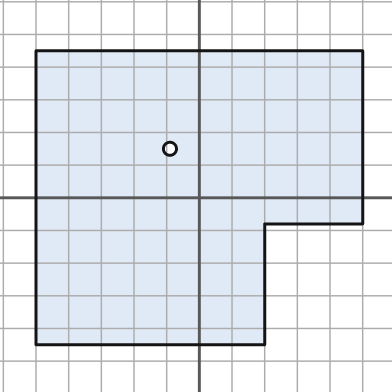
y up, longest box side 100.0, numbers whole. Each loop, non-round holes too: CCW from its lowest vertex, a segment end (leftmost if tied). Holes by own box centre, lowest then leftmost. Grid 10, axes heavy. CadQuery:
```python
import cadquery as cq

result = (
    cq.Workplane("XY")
    .moveTo(-50.0, -45.0)
    .lineTo(20.0, -45.0)
    .lineTo(20.0, -8.0)
    .lineTo(50.0, -8.0)
    .lineTo(50.0, 45.0)
    .lineTo(-50.0, 45.0)
    .close()
    .moveTo(-9.0, 15.0)
    .circle(2.0)
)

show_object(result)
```